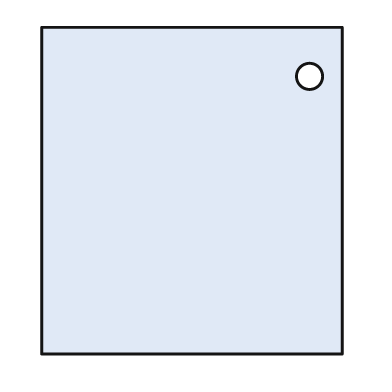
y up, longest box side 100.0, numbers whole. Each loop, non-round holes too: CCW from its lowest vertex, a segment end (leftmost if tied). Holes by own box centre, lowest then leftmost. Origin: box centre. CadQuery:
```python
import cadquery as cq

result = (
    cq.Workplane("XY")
    .moveTo(-46.0, -50.0)
    .lineTo(46.0, -50.0)
    .lineTo(46.0, 50.0)
    .lineTo(-46.0, 50.0)
    .close()
    .moveTo(36.0, 35.0)
    .circle(4.0)
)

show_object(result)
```